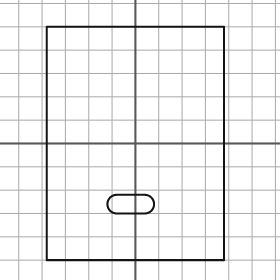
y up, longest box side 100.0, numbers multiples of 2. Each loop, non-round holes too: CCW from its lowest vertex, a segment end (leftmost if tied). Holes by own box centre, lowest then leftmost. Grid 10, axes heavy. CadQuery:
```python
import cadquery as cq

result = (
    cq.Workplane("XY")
    .moveTo(-38.0, -50.0)
    .lineTo(38.0, -50.0)
    .lineTo(38.0, 50.0)
    .lineTo(-38.0, 50.0)
    .close()
    .moveTo(-8.0, -30.0)
    .lineTo(4.0, -30.0)
    .threePointArc((8.0, -26.0), (4.0, -22.0))
    .lineTo(-8.0, -22.0)
    .threePointArc((-12.0, -26.0), (-8.0, -30.0))
    .close()
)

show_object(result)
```